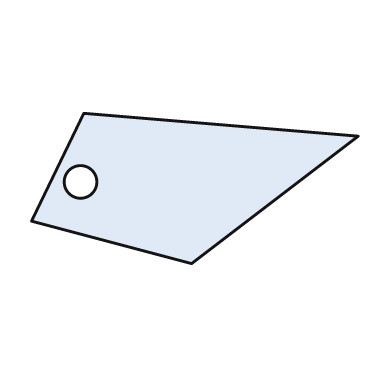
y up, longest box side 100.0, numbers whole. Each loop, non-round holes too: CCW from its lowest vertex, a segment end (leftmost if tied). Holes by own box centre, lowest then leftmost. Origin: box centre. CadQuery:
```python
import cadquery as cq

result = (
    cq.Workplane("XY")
    .moveTo(-1.0, -23.0)
    .lineTo(50.0, 16.0)
    .lineTo(-34.0, 23.0)
    .lineTo(-50.0, -10.0)
    .close()
    .moveTo(-35.0, 2.0)
    .circle(5.0)
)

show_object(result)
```